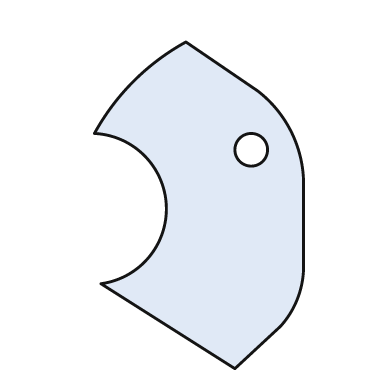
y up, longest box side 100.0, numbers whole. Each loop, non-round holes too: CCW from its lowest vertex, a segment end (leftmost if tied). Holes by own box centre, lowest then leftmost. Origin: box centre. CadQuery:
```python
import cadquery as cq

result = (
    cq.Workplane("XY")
    .moveTo(11.0, -50.0)
    .lineTo(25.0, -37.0)
    .threePointArc((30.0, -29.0), (32.0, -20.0))
    .lineTo(32.0, 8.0)
    .threePointArc((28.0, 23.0), (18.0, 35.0))
    .lineTo(-4.0, 50.0)
    .threePointArc((-20.0, 38.0), (-32.0, 22.0))
    .threePointArc((-10.0, 0.0), (-30.0, -24.0))
    .close()
    .moveTo(16.0, 17.0)
    .circle(5.0)
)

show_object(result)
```